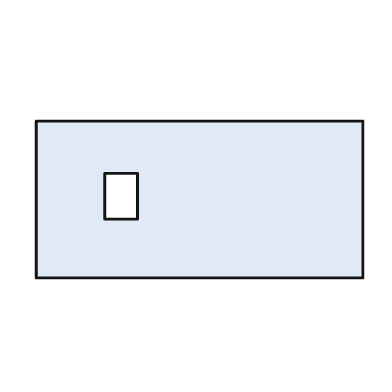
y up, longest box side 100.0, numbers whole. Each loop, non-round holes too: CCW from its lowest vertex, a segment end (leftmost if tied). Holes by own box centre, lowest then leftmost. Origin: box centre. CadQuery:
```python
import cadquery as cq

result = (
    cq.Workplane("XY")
    .moveTo(-50.0, -24.0)
    .lineTo(50.0, -24.0)
    .lineTo(50.0, 24.0)
    .lineTo(-50.0, 24.0)
    .close()
    .moveTo(-29.0, -6.0)
    .lineTo(-19.0, -6.0)
    .lineTo(-19.0, 8.0)
    .lineTo(-29.0, 8.0)
    .close()
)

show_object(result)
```